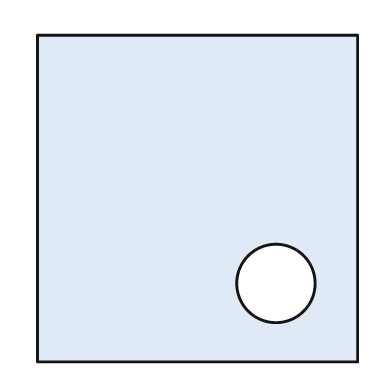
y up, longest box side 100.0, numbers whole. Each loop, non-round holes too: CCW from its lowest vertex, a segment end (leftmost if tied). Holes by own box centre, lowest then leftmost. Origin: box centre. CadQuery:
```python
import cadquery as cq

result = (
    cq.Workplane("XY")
    .moveTo(-49.0, -50.0)
    .lineTo(49.0, -50.0)
    .lineTo(49.0, 50.0)
    .lineTo(-49.0, 50.0)
    .close()
    .moveTo(24.0, -26.0)
    .circle(12.0)
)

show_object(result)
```